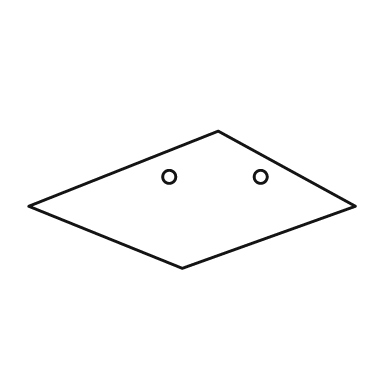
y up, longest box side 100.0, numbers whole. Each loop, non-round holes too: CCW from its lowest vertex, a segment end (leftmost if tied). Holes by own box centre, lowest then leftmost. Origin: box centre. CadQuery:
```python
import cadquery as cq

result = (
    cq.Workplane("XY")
    .moveTo(-3.0, -21.0)
    .lineTo(50.0, -2.0)
    .lineTo(8.0, 21.0)
    .lineTo(-50.0, -2.0)
    .close()
    .moveTo(-7.0, 7.0)
    .circle(2.0)
    .moveTo(21.0, 7.0)
    .circle(2.0)
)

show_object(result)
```